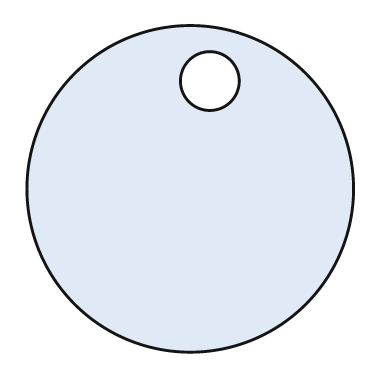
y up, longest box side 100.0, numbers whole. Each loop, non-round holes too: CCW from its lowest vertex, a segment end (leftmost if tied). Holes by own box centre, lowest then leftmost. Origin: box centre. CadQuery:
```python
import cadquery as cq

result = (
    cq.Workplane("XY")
    .moveTo(0.0, 0.0)
    .circle(50.0)
    .moveTo(6.0, 33.0)
    .circle(9.0)
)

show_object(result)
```